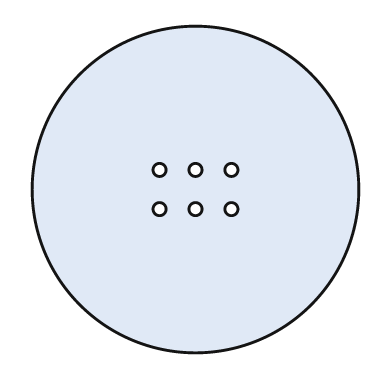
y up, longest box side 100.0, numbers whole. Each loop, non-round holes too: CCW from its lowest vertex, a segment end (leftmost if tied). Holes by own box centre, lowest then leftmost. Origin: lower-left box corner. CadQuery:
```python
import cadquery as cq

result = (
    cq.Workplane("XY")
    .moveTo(50.0, 50.0)
    .circle(50.0)
    .moveTo(39.0, 44.0)
    .circle(2.0)
    .moveTo(50.0, 44.0)
    .circle(2.0)
    .moveTo(61.0, 44.0)
    .circle(2.0)
    .moveTo(39.0, 56.0)
    .circle(2.0)
    .moveTo(50.0, 56.0)
    .circle(2.0)
    .moveTo(61.0, 56.0)
    .circle(2.0)
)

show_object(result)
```